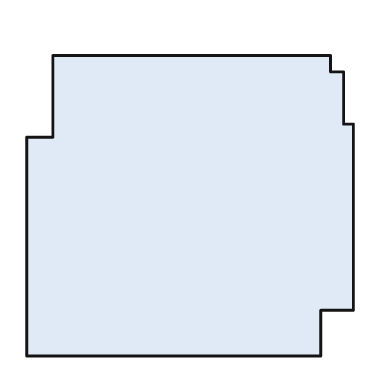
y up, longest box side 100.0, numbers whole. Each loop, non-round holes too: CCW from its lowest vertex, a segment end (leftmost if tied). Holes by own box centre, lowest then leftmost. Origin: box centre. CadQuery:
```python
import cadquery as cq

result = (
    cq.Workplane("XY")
    .moveTo(-50.0, -46.0)
    .lineTo(40.0, -46.0)
    .lineTo(40.0, -32.0)
    .lineTo(50.0, -32.0)
    .lineTo(50.0, 25.0)
    .lineTo(47.0, 25.0)
    .lineTo(47.0, 41.0)
    .lineTo(43.0, 41.0)
    .lineTo(43.0, 46.0)
    .lineTo(-42.0, 46.0)
    .lineTo(-42.0, 21.0)
    .lineTo(-50.0, 21.0)
    .close()
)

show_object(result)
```